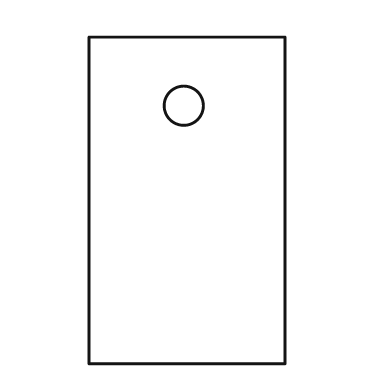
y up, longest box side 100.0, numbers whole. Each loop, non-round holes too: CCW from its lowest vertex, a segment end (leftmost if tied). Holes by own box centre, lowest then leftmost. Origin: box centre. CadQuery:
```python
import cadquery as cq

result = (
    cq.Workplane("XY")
    .moveTo(-30.0, -50.0)
    .lineTo(30.0, -50.0)
    .lineTo(30.0, 50.0)
    .lineTo(-30.0, 50.0)
    .close()
    .moveTo(-1.0, 29.0)
    .circle(6.0)
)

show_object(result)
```